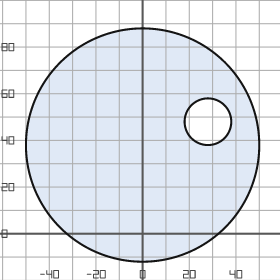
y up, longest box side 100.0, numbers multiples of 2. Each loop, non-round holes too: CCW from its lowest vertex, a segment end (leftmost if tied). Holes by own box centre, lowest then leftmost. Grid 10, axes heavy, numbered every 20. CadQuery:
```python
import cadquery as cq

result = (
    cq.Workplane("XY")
    .moveTo(0.0, 38.0)
    .circle(50.0)
    .moveTo(28.0, 48.0)
    .circle(10.0)
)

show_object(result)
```